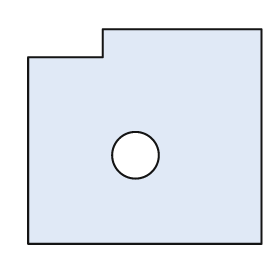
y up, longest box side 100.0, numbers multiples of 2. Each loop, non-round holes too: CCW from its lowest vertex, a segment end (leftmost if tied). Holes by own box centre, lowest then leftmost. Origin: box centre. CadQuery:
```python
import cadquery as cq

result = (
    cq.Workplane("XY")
    .moveTo(-50.0, -46.0)
    .lineTo(50.0, -46.0)
    .lineTo(50.0, 46.0)
    .lineTo(-18.0, 46.0)
    .lineTo(-18.0, 34.0)
    .lineTo(-50.0, 34.0)
    .close()
    .moveTo(-4.0, -8.0)
    .circle(10.0)
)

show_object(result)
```